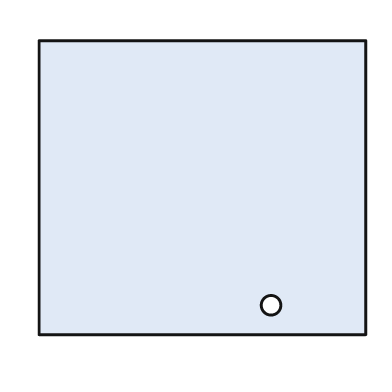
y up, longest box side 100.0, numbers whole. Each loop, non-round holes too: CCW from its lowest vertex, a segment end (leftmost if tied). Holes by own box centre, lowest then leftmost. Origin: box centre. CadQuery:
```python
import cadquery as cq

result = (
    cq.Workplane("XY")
    .moveTo(-50.0, -45.0)
    .lineTo(50.0, -45.0)
    .lineTo(50.0, 45.0)
    .lineTo(-50.0, 45.0)
    .close()
    .moveTo(21.0, -36.0)
    .circle(3.0)
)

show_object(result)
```